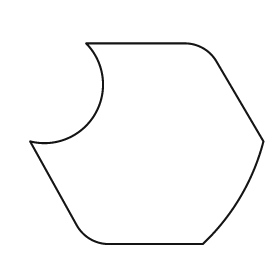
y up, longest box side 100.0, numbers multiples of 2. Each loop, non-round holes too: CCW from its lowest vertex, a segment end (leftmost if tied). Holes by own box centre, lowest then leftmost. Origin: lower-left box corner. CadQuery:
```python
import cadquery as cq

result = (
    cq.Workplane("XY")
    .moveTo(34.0, 0.0)
    .lineTo(74.0, 0.0)
    .threePointArc((90.0, 20.0), (100.0, 44.0))
    .lineTo(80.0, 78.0)
    .threePointArc((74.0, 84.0), (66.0, 86.0))
    .lineTo(24.0, 86.0)
    .threePointArc((28.0, 56.0), (0.0, 44.0))
    .lineTo(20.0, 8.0)
    .threePointArc((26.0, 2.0), (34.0, 0.0))
    .close()
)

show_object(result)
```